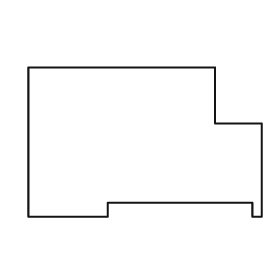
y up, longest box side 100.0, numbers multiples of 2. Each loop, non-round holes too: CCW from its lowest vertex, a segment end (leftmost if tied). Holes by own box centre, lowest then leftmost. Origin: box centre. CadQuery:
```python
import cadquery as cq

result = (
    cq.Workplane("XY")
    .moveTo(-50.0, -32.0)
    .lineTo(-16.0, -32.0)
    .lineTo(-16.0, -26.0)
    .lineTo(46.0, -26.0)
    .lineTo(46.0, -32.0)
    .lineTo(50.0, -32.0)
    .lineTo(50.0, 8.0)
    .lineTo(30.0, 8.0)
    .lineTo(30.0, 32.0)
    .lineTo(-50.0, 32.0)
    .close()
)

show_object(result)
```